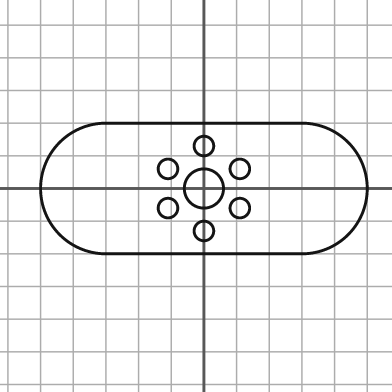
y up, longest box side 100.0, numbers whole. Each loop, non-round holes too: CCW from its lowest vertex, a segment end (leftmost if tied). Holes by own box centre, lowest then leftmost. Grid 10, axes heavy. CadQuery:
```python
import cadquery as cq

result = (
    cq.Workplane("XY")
    .moveTo(-30.0, -20.0)
    .lineTo(30.0, -20.0)
    .threePointArc((50.0, 0.0), (30.0, 20.0))
    .lineTo(-30.0, 20.0)
    .threePointArc((-50.0, 0.0), (-30.0, -20.0))
    .close()
    .moveTo(0.0, -13.0)
    .circle(3.0)
    .moveTo(-11.0, -6.0)
    .circle(3.0)
    .moveTo(11.0, -6.0)
    .circle(3.0)
    .moveTo(0.0, 0.0)
    .circle(6.0)
    .moveTo(-11.0, 6.0)
    .circle(3.0)
    .moveTo(11.0, 6.0)
    .circle(3.0)
    .moveTo(0.0, 13.0)
    .circle(3.0)
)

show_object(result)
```